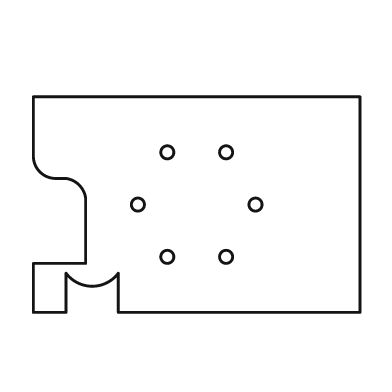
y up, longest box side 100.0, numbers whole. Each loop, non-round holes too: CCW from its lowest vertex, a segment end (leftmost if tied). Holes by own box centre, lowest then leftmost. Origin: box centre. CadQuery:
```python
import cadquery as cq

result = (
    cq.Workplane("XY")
    .moveTo(-50.0, -33.0)
    .lineTo(-40.0, -33.0)
    .lineTo(-40.0, -21.0)
    .threePointArc((-32.0, -25.0), (-24.0, -21.0))
    .lineTo(-24.0, -33.0)
    .lineTo(50.0, -33.0)
    .lineTo(50.0, 33.0)
    .lineTo(-50.0, 33.0)
    .lineTo(-50.0, 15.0)
    .threePointArc((-48.0, 10.0), (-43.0, 8.0))
    .lineTo(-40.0, 8.0)
    .threePointArc((-36.0, 6.0), (-34.0, 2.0))
    .lineTo(-34.0, -18.0)
    .lineTo(-50.0, -18.0)
    .close()
    .moveTo(-9.0, -16.0)
    .circle(2.0)
    .moveTo(9.0, -16.0)
    .circle(2.0)
    .moveTo(-18.0, 0.0)
    .circle(2.0)
    .moveTo(18.0, 0.0)
    .circle(2.0)
    .moveTo(-9.0, 16.0)
    .circle(2.0)
    .moveTo(9.0, 16.0)
    .circle(2.0)
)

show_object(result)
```